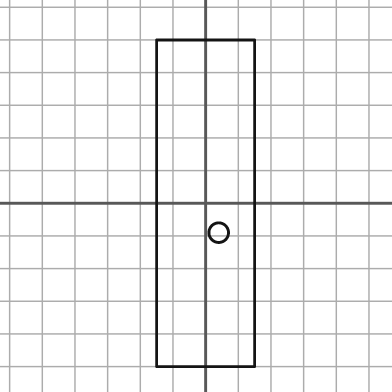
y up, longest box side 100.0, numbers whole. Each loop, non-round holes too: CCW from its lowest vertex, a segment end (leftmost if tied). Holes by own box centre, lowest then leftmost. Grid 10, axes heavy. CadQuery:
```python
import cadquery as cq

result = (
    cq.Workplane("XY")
    .moveTo(-15.0, -50.0)
    .lineTo(15.0, -50.0)
    .lineTo(15.0, 50.0)
    .lineTo(-15.0, 50.0)
    .close()
    .moveTo(4.0, -9.0)
    .circle(3.0)
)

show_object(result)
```